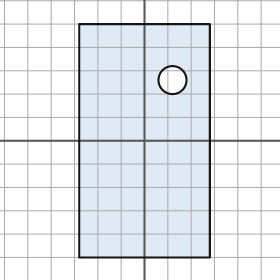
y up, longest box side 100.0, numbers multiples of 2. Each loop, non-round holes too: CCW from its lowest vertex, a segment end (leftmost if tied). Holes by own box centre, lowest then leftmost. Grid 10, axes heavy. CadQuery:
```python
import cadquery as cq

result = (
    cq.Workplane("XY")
    .moveTo(-28.0, -50.0)
    .lineTo(28.0, -50.0)
    .lineTo(28.0, 50.0)
    .lineTo(-28.0, 50.0)
    .close()
    .moveTo(12.0, 26.0)
    .circle(6.0)
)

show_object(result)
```